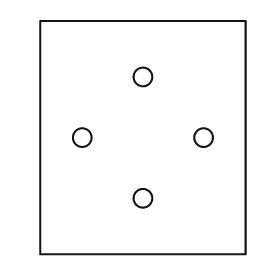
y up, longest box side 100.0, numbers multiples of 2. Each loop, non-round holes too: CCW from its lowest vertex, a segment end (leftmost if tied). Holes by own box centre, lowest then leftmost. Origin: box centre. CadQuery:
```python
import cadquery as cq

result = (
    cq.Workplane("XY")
    .moveTo(-44.0, -50.0)
    .lineTo(44.0, -50.0)
    .lineTo(44.0, 50.0)
    .lineTo(-44.0, 50.0)
    .close()
    .moveTo(0.0, -26.0)
    .circle(4.0)
    .moveTo(-26.0, 0.0)
    .circle(4.0)
    .moveTo(26.0, 0.0)
    .circle(4.0)
    .moveTo(0.0, 26.0)
    .circle(4.0)
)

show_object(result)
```